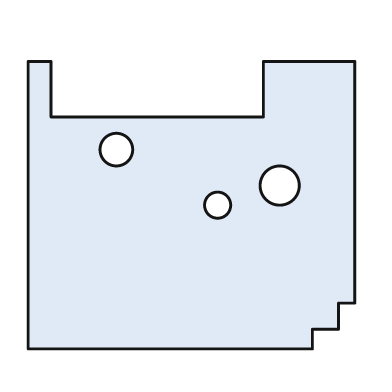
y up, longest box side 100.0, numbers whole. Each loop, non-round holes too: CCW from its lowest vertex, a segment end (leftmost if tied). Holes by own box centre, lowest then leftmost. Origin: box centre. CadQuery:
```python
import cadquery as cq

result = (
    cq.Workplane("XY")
    .moveTo(-50.0, -44.0)
    .lineTo(37.0, -44.0)
    .lineTo(37.0, -38.0)
    .lineTo(45.0, -38.0)
    .lineTo(45.0, -30.0)
    .lineTo(50.0, -30.0)
    .lineTo(50.0, 44.0)
    .lineTo(22.0, 44.0)
    .lineTo(22.0, 27.0)
    .lineTo(-43.0, 27.0)
    .lineTo(-43.0, 44.0)
    .lineTo(-50.0, 44.0)
    .close()
    .moveTo(8.0, 0.0)
    .circle(4.0)
    .moveTo(27.0, 6.0)
    .circle(6.0)
    .moveTo(-23.0, 17.0)
    .circle(5.0)
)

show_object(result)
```